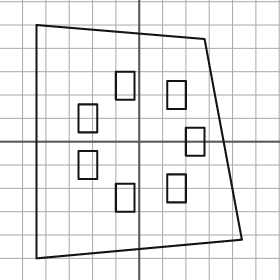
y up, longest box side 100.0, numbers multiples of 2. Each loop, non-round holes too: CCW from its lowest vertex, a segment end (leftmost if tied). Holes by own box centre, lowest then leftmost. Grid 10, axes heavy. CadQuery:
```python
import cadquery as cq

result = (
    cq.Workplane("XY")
    .moveTo(-44.0, -50.0)
    .lineTo(44.0, -42.0)
    .lineTo(28.0, 44.0)
    .lineTo(-44.0, 50.0)
    .close()
    .moveTo(-10.0, -30.0)
    .lineTo(-2.0, -30.0)
    .lineTo(-2.0, -18.0)
    .lineTo(-10.0, -18.0)
    .close()
    .moveTo(12.0, -26.0)
    .lineTo(20.0, -26.0)
    .lineTo(20.0, -14.0)
    .lineTo(12.0, -14.0)
    .close()
    .moveTo(-26.0, -16.0)
    .lineTo(-18.0, -16.0)
    .lineTo(-18.0, -4.0)
    .lineTo(-26.0, -4.0)
    .close()
    .moveTo(20.0, -6.0)
    .lineTo(28.0, -6.0)
    .lineTo(28.0, 6.0)
    .lineTo(20.0, 6.0)
    .close()
    .moveTo(-26.0, 4.0)
    .lineTo(-18.0, 4.0)
    .lineTo(-18.0, 16.0)
    .lineTo(-26.0, 16.0)
    .close()
    .moveTo(12.0, 14.0)
    .lineTo(20.0, 14.0)
    .lineTo(20.0, 26.0)
    .lineTo(12.0, 26.0)
    .close()
    .moveTo(-10.0, 18.0)
    .lineTo(-2.0, 18.0)
    .lineTo(-2.0, 30.0)
    .lineTo(-10.0, 30.0)
    .close()
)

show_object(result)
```